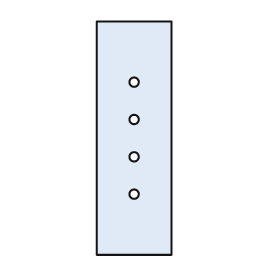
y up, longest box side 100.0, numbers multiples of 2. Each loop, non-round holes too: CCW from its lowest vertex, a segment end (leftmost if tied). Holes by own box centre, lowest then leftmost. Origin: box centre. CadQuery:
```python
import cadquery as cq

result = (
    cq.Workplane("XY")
    .moveTo(-16.0, -50.0)
    .lineTo(16.0, -50.0)
    .lineTo(16.0, 50.0)
    .lineTo(-16.0, 50.0)
    .close()
    .moveTo(0.0, -24.0)
    .circle(2.0)
    .moveTo(0.0, -8.0)
    .circle(2.0)
    .moveTo(0.0, 8.0)
    .circle(2.0)
    .moveTo(0.0, 24.0)
    .circle(2.0)
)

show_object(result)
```